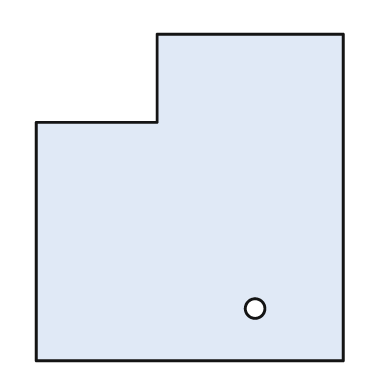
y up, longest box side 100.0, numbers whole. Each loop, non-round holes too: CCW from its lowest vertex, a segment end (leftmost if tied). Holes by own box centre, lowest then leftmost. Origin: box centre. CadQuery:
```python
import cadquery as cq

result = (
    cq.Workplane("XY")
    .moveTo(-47.0, -50.0)
    .lineTo(47.0, -50.0)
    .lineTo(47.0, 50.0)
    .lineTo(-10.0, 50.0)
    .lineTo(-10.0, 23.0)
    .lineTo(-47.0, 23.0)
    .close()
    .moveTo(20.0, -34.0)
    .circle(3.0)
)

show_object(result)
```